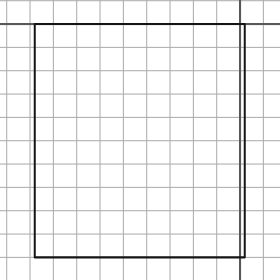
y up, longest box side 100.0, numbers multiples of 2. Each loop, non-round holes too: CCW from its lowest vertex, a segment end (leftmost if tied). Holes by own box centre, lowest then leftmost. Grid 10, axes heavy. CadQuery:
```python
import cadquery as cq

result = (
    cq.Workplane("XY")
    .moveTo(-88.0, -100.0)
    .lineTo(2.0, -100.0)
    .lineTo(2.0, 0.0)
    .lineTo(-88.0, 0.0)
    .close()
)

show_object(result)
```